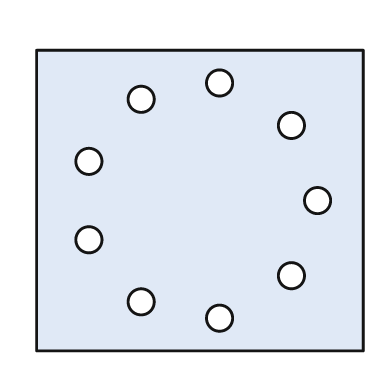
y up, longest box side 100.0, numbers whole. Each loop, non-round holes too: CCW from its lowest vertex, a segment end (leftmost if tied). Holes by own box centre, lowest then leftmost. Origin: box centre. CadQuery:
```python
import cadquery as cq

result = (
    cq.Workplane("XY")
    .moveTo(-50.0, -46.0)
    .lineTo(50.0, -46.0)
    .lineTo(50.0, 46.0)
    .lineTo(-50.0, 46.0)
    .close()
    .moveTo(6.0, -36.0)
    .circle(4.0)
    .moveTo(-18.0, -31.0)
    .circle(4.0)
    .moveTo(28.0, -23.0)
    .circle(4.0)
    .moveTo(-34.0, -12.0)
    .circle(4.0)
    .moveTo(36.0, 0.0)
    .circle(4.0)
    .moveTo(-34.0, 12.0)
    .circle(4.0)
    .moveTo(28.0, 23.0)
    .circle(4.0)
    .moveTo(-18.0, 31.0)
    .circle(4.0)
    .moveTo(6.0, 36.0)
    .circle(4.0)
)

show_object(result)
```